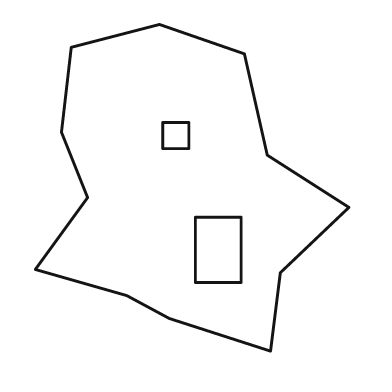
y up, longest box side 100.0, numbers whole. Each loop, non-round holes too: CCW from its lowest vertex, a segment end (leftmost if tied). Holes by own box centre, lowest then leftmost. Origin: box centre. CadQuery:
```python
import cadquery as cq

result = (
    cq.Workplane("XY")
    .moveTo(24.0, -50.0)
    .lineTo(27.0, -26.0)
    .lineTo(48.0, -6.0)
    .lineTo(23.0, 10.0)
    .lineTo(16.0, 41.0)
    .lineTo(-10.0, 50.0)
    .lineTo(-37.0, 43.0)
    .lineTo(-40.0, 17.0)
    .lineTo(-32.0, -3.0)
    .lineTo(-48.0, -25.0)
    .lineTo(-20.0, -33.0)
    .lineTo(-7.0, -40.0)
    .close()
    .moveTo(1.0, -29.0)
    .lineTo(15.0, -29.0)
    .lineTo(15.0, -9.0)
    .lineTo(1.0, -9.0)
    .close()
    .moveTo(-9.0, 12.0)
    .lineTo(-1.0, 12.0)
    .lineTo(-1.0, 20.0)
    .lineTo(-9.0, 20.0)
    .close()
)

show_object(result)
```